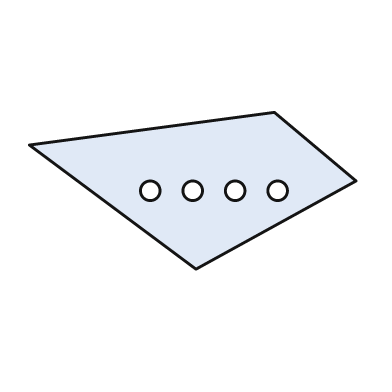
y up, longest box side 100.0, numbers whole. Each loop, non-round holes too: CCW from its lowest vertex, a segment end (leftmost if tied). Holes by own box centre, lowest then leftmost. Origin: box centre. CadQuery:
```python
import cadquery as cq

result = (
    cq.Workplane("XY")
    .moveTo(1.0, -24.0)
    .lineTo(50.0, 3.0)
    .lineTo(25.0, 24.0)
    .lineTo(-50.0, 14.0)
    .close()
    .moveTo(-13.0, 0.0)
    .circle(3.0)
    .moveTo(0.0, 0.0)
    .circle(3.0)
    .moveTo(13.0, 0.0)
    .circle(3.0)
    .moveTo(26.0, 0.0)
    .circle(3.0)
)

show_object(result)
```